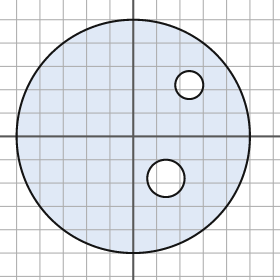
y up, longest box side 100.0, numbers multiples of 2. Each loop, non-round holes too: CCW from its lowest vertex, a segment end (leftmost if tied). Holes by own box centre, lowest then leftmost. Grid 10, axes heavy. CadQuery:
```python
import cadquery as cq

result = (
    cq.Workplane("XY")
    .moveTo(0.0, 0.0)
    .circle(50.0)
    .moveTo(14.0, -18.0)
    .circle(8.0)
    .moveTo(24.0, 22.0)
    .circle(6.0)
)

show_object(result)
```